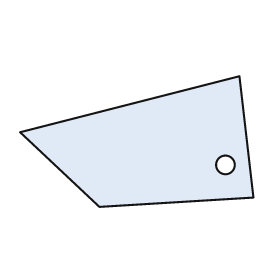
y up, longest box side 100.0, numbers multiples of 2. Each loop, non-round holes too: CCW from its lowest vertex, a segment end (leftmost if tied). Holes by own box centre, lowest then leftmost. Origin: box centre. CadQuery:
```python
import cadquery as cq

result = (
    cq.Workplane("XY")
    .moveTo(-16.0, -28.0)
    .lineTo(50.0, -24.0)
    .lineTo(44.0, 28.0)
    .lineTo(-50.0, 4.0)
    .close()
    .moveTo(38.0, -10.0)
    .circle(4.0)
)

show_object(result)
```